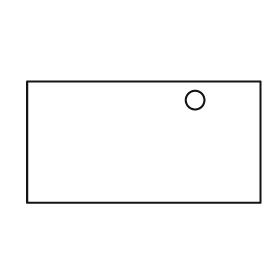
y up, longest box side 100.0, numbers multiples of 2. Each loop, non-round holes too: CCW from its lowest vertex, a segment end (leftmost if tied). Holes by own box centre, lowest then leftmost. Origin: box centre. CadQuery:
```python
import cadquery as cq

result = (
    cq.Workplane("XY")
    .moveTo(-50.0, -26.0)
    .lineTo(50.0, -26.0)
    .lineTo(50.0, 26.0)
    .lineTo(-50.0, 26.0)
    .close()
    .moveTo(22.0, 18.0)
    .circle(4.0)
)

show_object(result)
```